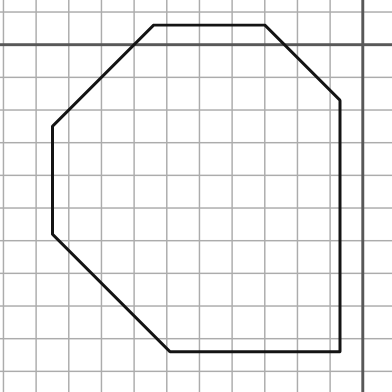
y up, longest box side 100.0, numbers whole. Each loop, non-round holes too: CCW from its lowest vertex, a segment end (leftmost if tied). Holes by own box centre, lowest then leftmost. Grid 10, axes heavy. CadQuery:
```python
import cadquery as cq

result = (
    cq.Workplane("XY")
    .moveTo(-59.0, -94.0)
    .lineTo(-7.0, -94.0)
    .lineTo(-7.0, -17.0)
    .lineTo(-30.0, 6.0)
    .lineTo(-64.0, 6.0)
    .lineTo(-95.0, -25.0)
    .lineTo(-95.0, -58.0)
    .close()
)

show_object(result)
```